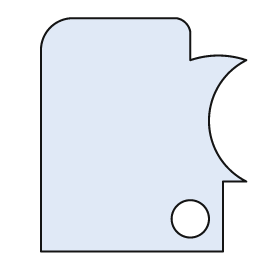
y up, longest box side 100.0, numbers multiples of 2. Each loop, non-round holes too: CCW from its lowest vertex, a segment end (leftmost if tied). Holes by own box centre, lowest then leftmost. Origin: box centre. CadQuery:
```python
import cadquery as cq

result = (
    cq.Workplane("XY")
    .moveTo(-44.0, -50.0)
    .lineTo(34.0, -50.0)
    .lineTo(34.0, -20.0)
    .lineTo(44.0, -20.0)
    .threePointArc((28.0, 6.0), (44.0, 32.0))
    .threePointArc((32.0, 34.0), (20.0, 32.0))
    .lineTo(20.0, 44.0)
    .threePointArc((18.0, 48.0), (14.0, 50.0))
    .lineTo(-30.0, 50.0)
    .threePointArc((-40.0, 46.0), (-44.0, 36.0))
    .close()
    .moveTo(20.0, -36.0)
    .circle(8.0)
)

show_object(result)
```